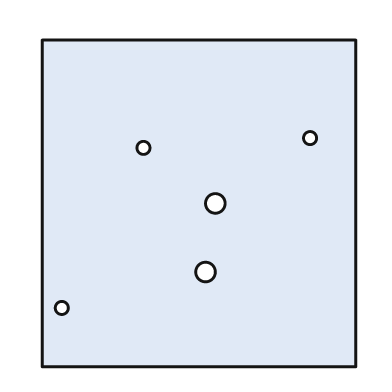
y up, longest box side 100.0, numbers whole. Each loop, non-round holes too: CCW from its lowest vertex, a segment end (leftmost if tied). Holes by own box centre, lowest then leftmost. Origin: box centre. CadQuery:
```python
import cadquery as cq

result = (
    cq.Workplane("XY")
    .moveTo(-48.0, -50.0)
    .lineTo(48.0, -50.0)
    .lineTo(48.0, 50.0)
    .lineTo(-48.0, 50.0)
    .close()
    .moveTo(-42.0, -32.0)
    .circle(2.0)
    .moveTo(2.0, -21.0)
    .circle(3.0)
    .moveTo(5.0, 0.0)
    .circle(3.0)
    .moveTo(-17.0, 17.0)
    .circle(2.0)
    .moveTo(34.0, 20.0)
    .circle(2.0)
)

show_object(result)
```